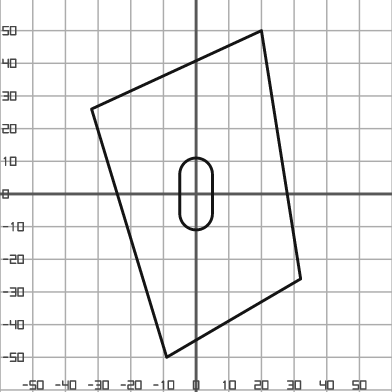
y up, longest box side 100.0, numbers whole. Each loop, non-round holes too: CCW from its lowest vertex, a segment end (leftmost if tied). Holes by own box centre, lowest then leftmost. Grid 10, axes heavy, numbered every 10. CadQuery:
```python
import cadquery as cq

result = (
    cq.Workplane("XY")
    .moveTo(-9.0, -50.0)
    .lineTo(32.0, -26.0)
    .lineTo(20.0, 50.0)
    .lineTo(-32.0, 26.0)
    .close()
    .moveTo(-5.0, -6.0)
    .threePointArc((0.0, -11.0), (5.0, -6.0))
    .lineTo(5.0, 6.0)
    .threePointArc((0.0, 11.0), (-5.0, 6.0))
    .close()
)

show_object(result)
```